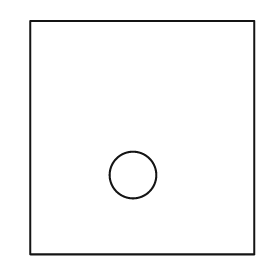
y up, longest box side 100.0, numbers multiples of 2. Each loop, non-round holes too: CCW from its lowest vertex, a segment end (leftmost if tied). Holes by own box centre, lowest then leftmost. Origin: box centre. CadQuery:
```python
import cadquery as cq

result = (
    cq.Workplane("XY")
    .moveTo(-48.0, -50.0)
    .lineTo(48.0, -50.0)
    .lineTo(48.0, 50.0)
    .lineTo(-48.0, 50.0)
    .close()
    .moveTo(-4.0, -16.0)
    .circle(10.0)
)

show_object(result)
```